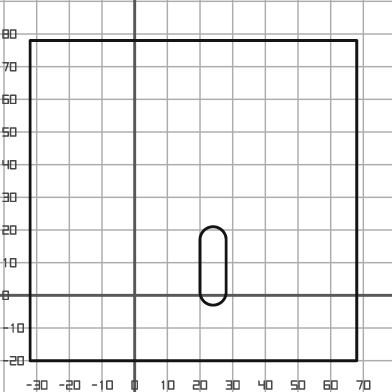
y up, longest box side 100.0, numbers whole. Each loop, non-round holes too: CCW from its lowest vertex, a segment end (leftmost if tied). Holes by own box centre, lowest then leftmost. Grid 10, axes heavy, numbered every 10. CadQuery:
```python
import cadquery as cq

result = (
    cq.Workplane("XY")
    .moveTo(-32.0, -20.0)
    .lineTo(68.0, -20.0)
    .lineTo(68.0, 78.0)
    .lineTo(-32.0, 78.0)
    .close()
    .moveTo(20.0, 1.0)
    .threePointArc((24.0, -3.0), (28.0, 1.0))
    .lineTo(28.0, 17.0)
    .threePointArc((24.0, 21.0), (20.0, 17.0))
    .close()
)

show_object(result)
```